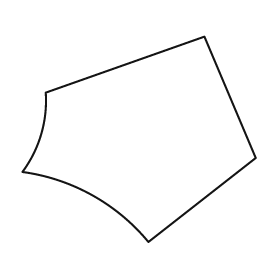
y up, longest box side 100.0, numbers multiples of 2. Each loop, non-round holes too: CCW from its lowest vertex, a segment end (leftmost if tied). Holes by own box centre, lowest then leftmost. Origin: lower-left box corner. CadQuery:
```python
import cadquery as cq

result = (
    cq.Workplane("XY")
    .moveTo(54.0, 0.0)
    .lineTo(100.0, 36.0)
    .lineTo(78.0, 88.0)
    .lineTo(10.0, 64.0)
    .threePointArc((8.0, 46.0), (0.0, 30.0))
    .threePointArc((30.0, 20.0), (54.0, 0.0))
    .close()
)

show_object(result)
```